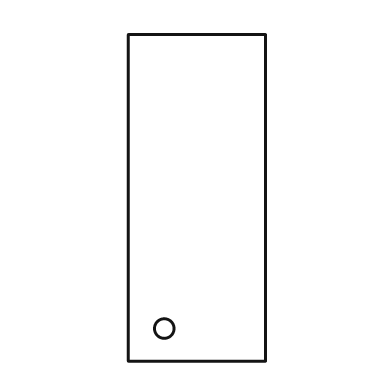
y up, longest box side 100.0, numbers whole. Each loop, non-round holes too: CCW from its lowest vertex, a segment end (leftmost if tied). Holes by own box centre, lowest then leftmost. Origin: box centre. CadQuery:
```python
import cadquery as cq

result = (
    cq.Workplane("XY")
    .moveTo(-21.0, -50.0)
    .lineTo(21.0, -50.0)
    .lineTo(21.0, 50.0)
    .lineTo(-21.0, 50.0)
    .close()
    .moveTo(-10.0, -40.0)
    .circle(3.0)
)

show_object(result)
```